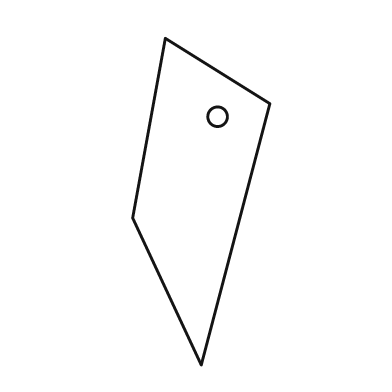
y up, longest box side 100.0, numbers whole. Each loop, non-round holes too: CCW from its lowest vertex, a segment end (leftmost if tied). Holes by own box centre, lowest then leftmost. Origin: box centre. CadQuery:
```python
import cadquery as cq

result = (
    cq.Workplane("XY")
    .moveTo(0.0, -50.0)
    .lineTo(21.0, 30.0)
    .lineTo(-11.0, 50.0)
    .lineTo(-21.0, -5.0)
    .close()
    .moveTo(5.0, 26.0)
    .circle(3.0)
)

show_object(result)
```